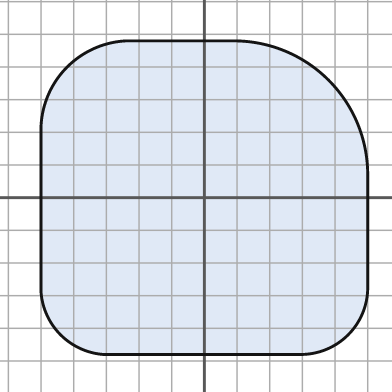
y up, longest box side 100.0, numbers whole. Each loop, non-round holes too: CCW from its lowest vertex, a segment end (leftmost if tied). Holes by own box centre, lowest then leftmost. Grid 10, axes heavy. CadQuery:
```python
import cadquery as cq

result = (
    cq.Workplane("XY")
    .moveTo(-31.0, -48.0)
    .lineTo(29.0, -48.0)
    .threePointArc((44.0, -42.0), (50.0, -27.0))
    .lineTo(50.0, 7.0)
    .threePointArc((38.0, 36.0), (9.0, 48.0))
    .lineTo(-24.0, 48.0)
    .threePointArc((-42.0, 40.0), (-50.0, 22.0))
    .lineTo(-50.0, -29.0)
    .threePointArc((-44.0, -42.0), (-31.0, -48.0))
    .close()
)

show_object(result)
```